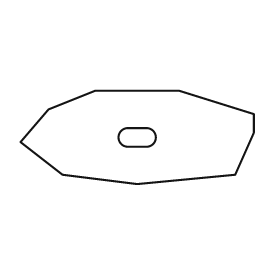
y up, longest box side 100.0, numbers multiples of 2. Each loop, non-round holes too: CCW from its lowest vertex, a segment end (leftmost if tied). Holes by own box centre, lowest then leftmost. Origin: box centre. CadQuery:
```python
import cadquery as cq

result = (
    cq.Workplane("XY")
    .moveTo(0.0, -20.0)
    .lineTo(42.0, -16.0)
    .lineTo(50.0, 2.0)
    .lineTo(50.0, 10.0)
    .lineTo(18.0, 20.0)
    .lineTo(-18.0, 20.0)
    .lineTo(-38.0, 12.0)
    .lineTo(-50.0, -2.0)
    .lineTo(-32.0, -16.0)
    .close()
    .moveTo(-4.0, -4.0)
    .lineTo(4.0, -4.0)
    .threePointArc((8.0, 0.0), (4.0, 4.0))
    .lineTo(-4.0, 4.0)
    .threePointArc((-8.0, 0.0), (-4.0, -4.0))
    .close()
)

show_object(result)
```